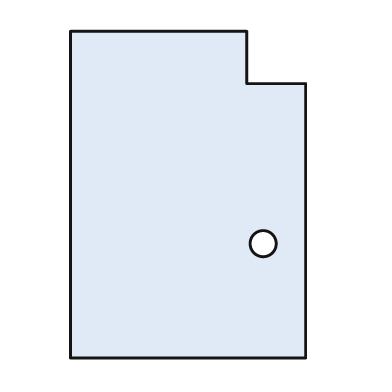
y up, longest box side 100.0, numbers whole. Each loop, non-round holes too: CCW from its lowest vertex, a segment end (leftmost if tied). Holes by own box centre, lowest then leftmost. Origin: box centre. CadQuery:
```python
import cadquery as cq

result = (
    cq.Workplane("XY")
    .moveTo(-36.0, -50.0)
    .lineTo(36.0, -50.0)
    .lineTo(36.0, 34.0)
    .lineTo(18.0, 34.0)
    .lineTo(18.0, 50.0)
    .lineTo(-36.0, 50.0)
    .close()
    .moveTo(23.0, -15.0)
    .circle(4.0)
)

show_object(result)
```